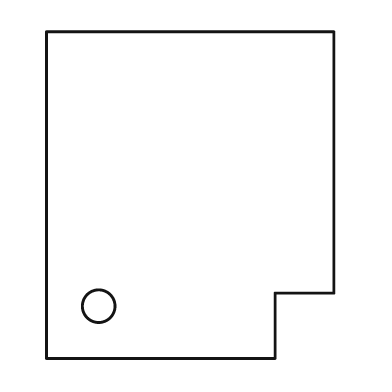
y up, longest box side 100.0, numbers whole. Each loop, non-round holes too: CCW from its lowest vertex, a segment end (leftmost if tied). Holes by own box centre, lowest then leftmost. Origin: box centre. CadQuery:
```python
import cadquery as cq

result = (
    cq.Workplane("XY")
    .moveTo(-44.0, -50.0)
    .lineTo(26.0, -50.0)
    .lineTo(26.0, -30.0)
    .lineTo(44.0, -30.0)
    .lineTo(44.0, 50.0)
    .lineTo(-44.0, 50.0)
    .close()
    .moveTo(-28.0, -34.0)
    .circle(5.0)
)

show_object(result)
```